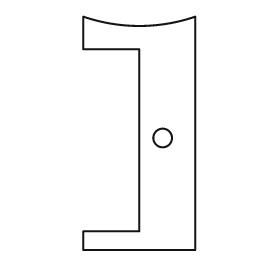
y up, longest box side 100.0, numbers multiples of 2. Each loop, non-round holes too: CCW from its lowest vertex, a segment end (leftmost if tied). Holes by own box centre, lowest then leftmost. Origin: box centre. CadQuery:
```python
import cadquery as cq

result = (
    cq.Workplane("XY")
    .moveTo(-24.0, -50.0)
    .lineTo(24.0, -50.0)
    .lineTo(24.0, 50.0)
    .threePointArc((0.0, 46.0), (-24.0, 50.0))
    .lineTo(-24.0, 36.0)
    .lineTo(0.0, 36.0)
    .lineTo(0.0, -42.0)
    .lineTo(-24.0, -42.0)
    .close()
    .moveTo(10.0, -2.0)
    .circle(4.0)
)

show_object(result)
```